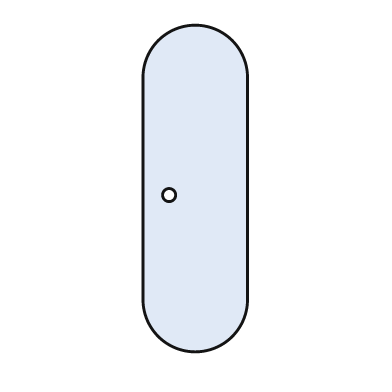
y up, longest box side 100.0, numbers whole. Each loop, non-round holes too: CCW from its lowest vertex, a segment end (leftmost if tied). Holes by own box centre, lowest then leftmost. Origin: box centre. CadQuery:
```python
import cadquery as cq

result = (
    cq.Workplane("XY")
    .moveTo(-16.0, -34.0)
    .threePointArc((0.0, -50.0), (16.0, -34.0))
    .lineTo(16.0, 34.0)
    .threePointArc((0.0, 50.0), (-16.0, 34.0))
    .close()
    .moveTo(-8.0, -2.0)
    .circle(2.0)
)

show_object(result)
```